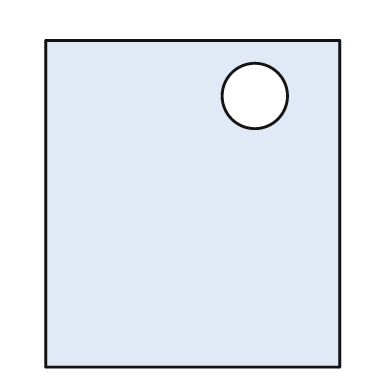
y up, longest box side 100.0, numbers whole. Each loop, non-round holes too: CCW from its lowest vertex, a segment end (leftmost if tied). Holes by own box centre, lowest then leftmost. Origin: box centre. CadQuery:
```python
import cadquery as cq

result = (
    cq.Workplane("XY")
    .moveTo(-45.0, -50.0)
    .lineTo(45.0, -50.0)
    .lineTo(45.0, 50.0)
    .lineTo(-45.0, 50.0)
    .close()
    .moveTo(19.0, 33.0)
    .circle(10.0)
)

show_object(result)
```